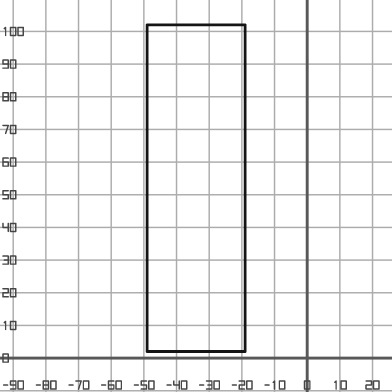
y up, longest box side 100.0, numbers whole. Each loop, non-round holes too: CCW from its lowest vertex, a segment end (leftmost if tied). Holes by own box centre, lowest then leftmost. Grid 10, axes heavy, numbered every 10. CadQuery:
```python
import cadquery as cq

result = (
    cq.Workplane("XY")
    .moveTo(-49.0, 2.0)
    .lineTo(-19.0, 2.0)
    .lineTo(-19.0, 102.0)
    .lineTo(-49.0, 102.0)
    .close()
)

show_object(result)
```